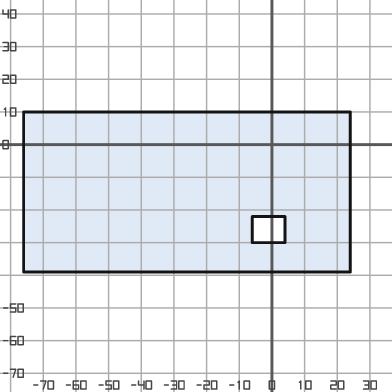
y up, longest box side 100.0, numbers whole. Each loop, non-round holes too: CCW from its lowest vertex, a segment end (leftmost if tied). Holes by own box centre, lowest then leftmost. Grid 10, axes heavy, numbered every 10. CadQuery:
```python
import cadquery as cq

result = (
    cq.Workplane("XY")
    .moveTo(-76.0, -39.0)
    .lineTo(24.0, -39.0)
    .lineTo(24.0, 10.0)
    .lineTo(-76.0, 10.0)
    .close()
    .moveTo(-6.0, -30.0)
    .lineTo(4.0, -30.0)
    .lineTo(4.0, -22.0)
    .lineTo(-6.0, -22.0)
    .close()
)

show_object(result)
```